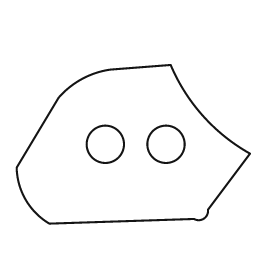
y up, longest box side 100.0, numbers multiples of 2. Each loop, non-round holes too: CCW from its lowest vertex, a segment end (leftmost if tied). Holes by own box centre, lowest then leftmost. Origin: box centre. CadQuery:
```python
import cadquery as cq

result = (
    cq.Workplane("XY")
    .moveTo(-36.0, -34.0)
    .lineTo(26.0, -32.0)
    .threePointArc((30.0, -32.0), (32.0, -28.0))
    .lineTo(50.0, -4.0)
    .threePointArc((30.0, 12.0), (16.0, 34.0))
    .lineTo(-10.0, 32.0)
    .threePointArc((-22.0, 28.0), (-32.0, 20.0))
    .lineTo(-50.0, -10.0)
    .threePointArc((-46.0, -24.0), (-36.0, -34.0))
    .close()
    .moveTo(-12.0, 0.0)
    .circle(8.0)
    .moveTo(14.0, 0.0)
    .circle(8.0)
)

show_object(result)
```